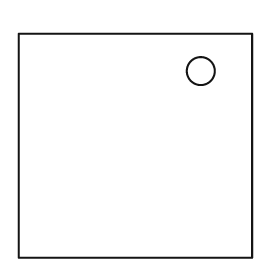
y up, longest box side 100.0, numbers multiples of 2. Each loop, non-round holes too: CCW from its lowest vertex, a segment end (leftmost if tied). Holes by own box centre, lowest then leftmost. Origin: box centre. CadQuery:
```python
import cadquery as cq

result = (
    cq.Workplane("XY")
    .moveTo(-50.0, -48.0)
    .lineTo(50.0, -48.0)
    .lineTo(50.0, 48.0)
    .lineTo(-50.0, 48.0)
    .close()
    .moveTo(28.0, 32.0)
    .circle(6.0)
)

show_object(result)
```